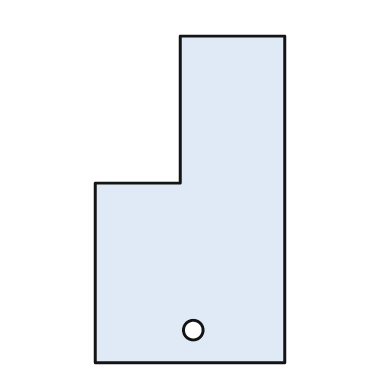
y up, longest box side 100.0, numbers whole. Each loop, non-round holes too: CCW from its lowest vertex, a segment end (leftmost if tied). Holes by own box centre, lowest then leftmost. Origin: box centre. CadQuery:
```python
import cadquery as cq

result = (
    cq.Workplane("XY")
    .moveTo(-29.0, -50.0)
    .lineTo(29.0, -50.0)
    .lineTo(29.0, 50.0)
    .lineTo(-3.0, 50.0)
    .lineTo(-3.0, 5.0)
    .lineTo(-29.0, 5.0)
    .close()
    .moveTo(1.0, -40.0)
    .circle(3.0)
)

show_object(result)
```